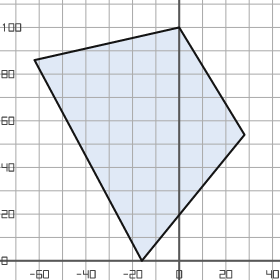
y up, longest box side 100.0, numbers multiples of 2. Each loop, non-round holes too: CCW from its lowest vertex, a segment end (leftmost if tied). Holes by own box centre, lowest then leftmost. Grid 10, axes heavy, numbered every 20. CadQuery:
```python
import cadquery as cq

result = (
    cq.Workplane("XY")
    .moveTo(-16.0, 0.0)
    .lineTo(28.0, 54.0)
    .lineTo(0.0, 100.0)
    .lineTo(-62.0, 86.0)
    .close()
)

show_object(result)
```